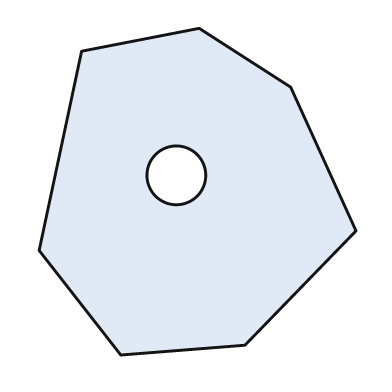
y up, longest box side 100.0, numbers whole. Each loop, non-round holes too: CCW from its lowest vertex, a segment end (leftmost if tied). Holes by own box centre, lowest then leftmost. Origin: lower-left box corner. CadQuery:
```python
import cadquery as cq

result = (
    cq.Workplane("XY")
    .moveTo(25.0, 0.0)
    .lineTo(63.0, 3.0)
    .lineTo(97.0, 38.0)
    .lineTo(77.0, 82.0)
    .lineTo(49.0, 100.0)
    .lineTo(13.0, 93.0)
    .lineTo(0.0, 32.0)
    .close()
    .moveTo(42.0, 55.0)
    .circle(9.0)
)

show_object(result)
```